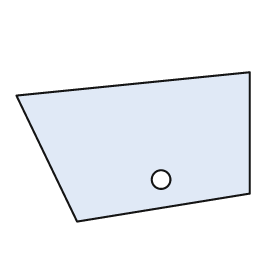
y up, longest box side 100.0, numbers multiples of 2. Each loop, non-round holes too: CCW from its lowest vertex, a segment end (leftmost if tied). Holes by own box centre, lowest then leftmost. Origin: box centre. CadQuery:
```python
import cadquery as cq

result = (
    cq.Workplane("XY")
    .moveTo(-24.0, -32.0)
    .lineTo(50.0, -20.0)
    .lineTo(50.0, 32.0)
    .lineTo(-50.0, 22.0)
    .close()
    .moveTo(12.0, -14.0)
    .circle(4.0)
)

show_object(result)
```